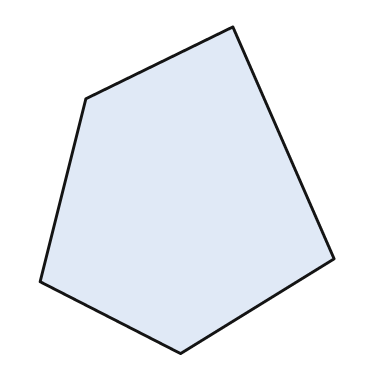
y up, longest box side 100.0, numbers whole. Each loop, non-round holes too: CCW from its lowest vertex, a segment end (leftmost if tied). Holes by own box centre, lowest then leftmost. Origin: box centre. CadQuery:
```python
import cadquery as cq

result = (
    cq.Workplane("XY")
    .moveTo(-2.0, -50.0)
    .lineTo(45.0, -21.0)
    .lineTo(14.0, 50.0)
    .lineTo(-31.0, 28.0)
    .lineTo(-45.0, -28.0)
    .close()
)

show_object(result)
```